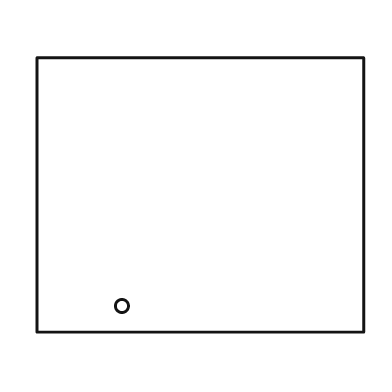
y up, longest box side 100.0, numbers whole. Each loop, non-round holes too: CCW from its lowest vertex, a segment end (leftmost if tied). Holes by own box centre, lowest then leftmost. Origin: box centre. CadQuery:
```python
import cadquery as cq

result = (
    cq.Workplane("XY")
    .moveTo(-50.0, -42.0)
    .lineTo(50.0, -42.0)
    .lineTo(50.0, 42.0)
    .lineTo(-50.0, 42.0)
    .close()
    .moveTo(-24.0, -34.0)
    .circle(2.0)
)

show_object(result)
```